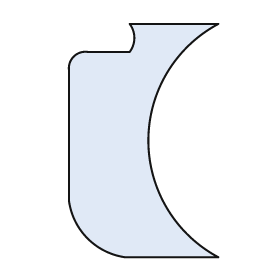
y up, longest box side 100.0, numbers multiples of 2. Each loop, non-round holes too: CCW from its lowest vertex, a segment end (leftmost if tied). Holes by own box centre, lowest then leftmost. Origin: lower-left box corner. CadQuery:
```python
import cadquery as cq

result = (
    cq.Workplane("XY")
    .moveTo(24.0, 0.0)
    .lineTo(64.0, 0.0)
    .threePointArc((34.0, 50.0), (64.0, 100.0))
    .lineTo(26.0, 100.0)
    .threePointArc((28.0, 94.0), (26.0, 88.0))
    .lineTo(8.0, 88.0)
    .threePointArc((2.0, 86.0), (0.0, 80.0))
    .lineTo(0.0, 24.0)
    .threePointArc((8.0, 8.0), (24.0, 0.0))
    .close()
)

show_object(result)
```